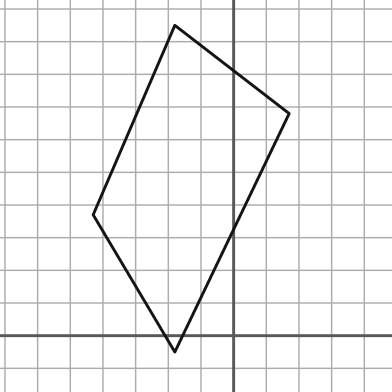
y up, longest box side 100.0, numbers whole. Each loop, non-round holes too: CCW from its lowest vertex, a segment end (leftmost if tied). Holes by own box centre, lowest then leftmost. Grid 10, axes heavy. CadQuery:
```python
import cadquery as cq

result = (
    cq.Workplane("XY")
    .moveTo(-18.0, -5.0)
    .lineTo(17.0, 68.0)
    .lineTo(-18.0, 95.0)
    .lineTo(-43.0, 37.0)
    .close()
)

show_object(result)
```